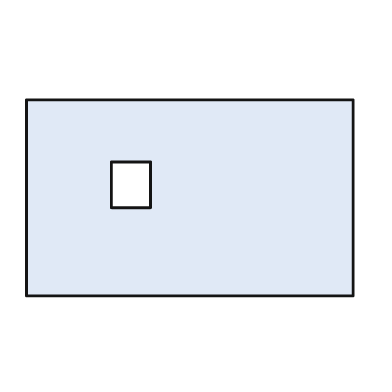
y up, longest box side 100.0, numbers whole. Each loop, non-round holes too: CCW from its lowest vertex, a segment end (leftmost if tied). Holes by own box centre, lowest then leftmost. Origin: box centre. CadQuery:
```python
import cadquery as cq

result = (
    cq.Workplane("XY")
    .moveTo(-50.0, -30.0)
    .lineTo(50.0, -30.0)
    .lineTo(50.0, 30.0)
    .lineTo(-50.0, 30.0)
    .close()
    .moveTo(-24.0, -3.0)
    .lineTo(-12.0, -3.0)
    .lineTo(-12.0, 11.0)
    .lineTo(-24.0, 11.0)
    .close()
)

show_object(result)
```